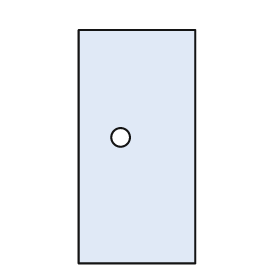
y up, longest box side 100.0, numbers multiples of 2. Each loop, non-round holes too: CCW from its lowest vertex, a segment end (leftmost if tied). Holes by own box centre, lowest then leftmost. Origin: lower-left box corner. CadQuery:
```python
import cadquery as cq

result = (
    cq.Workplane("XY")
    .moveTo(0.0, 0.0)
    .lineTo(50.0, 0.0)
    .lineTo(50.0, 100.0)
    .lineTo(0.0, 100.0)
    .close()
    .moveTo(18.0, 54.0)
    .circle(4.0)
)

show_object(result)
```